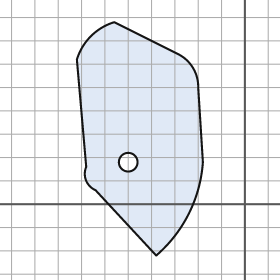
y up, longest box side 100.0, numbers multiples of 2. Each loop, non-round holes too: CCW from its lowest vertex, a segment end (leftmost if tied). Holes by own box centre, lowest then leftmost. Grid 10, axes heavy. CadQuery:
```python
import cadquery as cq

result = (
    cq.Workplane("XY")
    .moveTo(-38.0, -22.0)
    .threePointArc((-24.0, -4.0), (-18.0, 18.0))
    .lineTo(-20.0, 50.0)
    .threePointArc((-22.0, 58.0), (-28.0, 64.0))
    .lineTo(-56.0, 78.0)
    .threePointArc((-66.0, 72.0), (-72.0, 62.0))
    .lineTo(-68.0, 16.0)
    .threePointArc((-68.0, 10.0), (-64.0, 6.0))
    .close()
    .moveTo(-50.0, 18.0)
    .circle(4.0)
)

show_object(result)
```